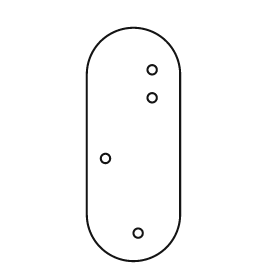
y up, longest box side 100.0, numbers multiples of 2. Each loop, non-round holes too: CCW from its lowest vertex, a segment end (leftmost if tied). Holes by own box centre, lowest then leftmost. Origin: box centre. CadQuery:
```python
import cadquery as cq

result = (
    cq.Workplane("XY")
    .moveTo(-20.0, -30.0)
    .threePointArc((0.0, -50.0), (20.0, -30.0))
    .lineTo(20.0, 30.0)
    .threePointArc((0.0, 50.0), (-20.0, 30.0))
    .close()
    .moveTo(2.0, -38.0)
    .circle(2.0)
    .moveTo(-12.0, -6.0)
    .circle(2.0)
    .moveTo(8.0, 20.0)
    .circle(2.0)
    .moveTo(8.0, 32.0)
    .circle(2.0)
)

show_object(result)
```